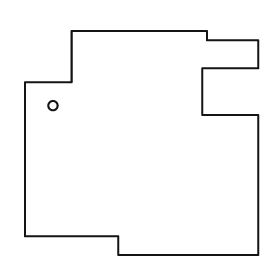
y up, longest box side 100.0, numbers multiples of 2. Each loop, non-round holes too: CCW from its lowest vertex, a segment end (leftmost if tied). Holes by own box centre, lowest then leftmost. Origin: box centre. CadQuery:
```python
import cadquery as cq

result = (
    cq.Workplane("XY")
    .moveTo(-10.0, -48.0)
    .lineTo(50.0, -48.0)
    .lineTo(50.0, 12.0)
    .lineTo(26.0, 12.0)
    .lineTo(26.0, 32.0)
    .lineTo(50.0, 32.0)
    .lineTo(50.0, 44.0)
    .lineTo(28.0, 44.0)
    .lineTo(28.0, 48.0)
    .lineTo(-30.0, 48.0)
    .lineTo(-30.0, 26.0)
    .lineTo(-50.0, 26.0)
    .lineTo(-50.0, -40.0)
    .lineTo(-10.0, -40.0)
    .close()
    .moveTo(-38.0, 16.0)
    .circle(2.0)
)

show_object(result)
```